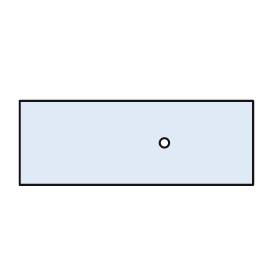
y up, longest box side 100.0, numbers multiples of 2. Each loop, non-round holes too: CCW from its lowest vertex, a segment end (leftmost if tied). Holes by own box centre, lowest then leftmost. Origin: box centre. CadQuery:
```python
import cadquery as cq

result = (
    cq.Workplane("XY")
    .moveTo(-50.0, -18.0)
    .lineTo(50.0, -18.0)
    .lineTo(50.0, 18.0)
    .lineTo(-50.0, 18.0)
    .close()
    .moveTo(12.0, 0.0)
    .circle(2.0)
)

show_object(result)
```